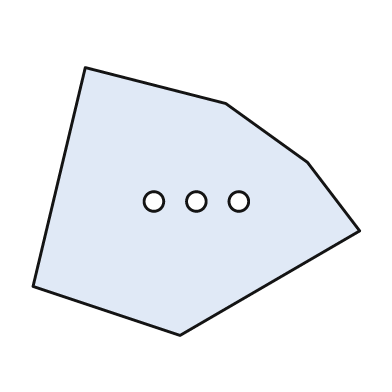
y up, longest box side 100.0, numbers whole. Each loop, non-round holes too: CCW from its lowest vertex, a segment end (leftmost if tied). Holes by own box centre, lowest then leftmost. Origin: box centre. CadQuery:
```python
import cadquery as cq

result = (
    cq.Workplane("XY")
    .moveTo(-5.0, -41.0)
    .lineTo(50.0, -9.0)
    .lineTo(34.0, 12.0)
    .lineTo(9.0, 30.0)
    .lineTo(-34.0, 41.0)
    .lineTo(-50.0, -26.0)
    .close()
    .moveTo(-13.0, 0.0)
    .circle(3.0)
    .moveTo(0.0, 0.0)
    .circle(3.0)
    .moveTo(13.0, 0.0)
    .circle(3.0)
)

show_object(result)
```